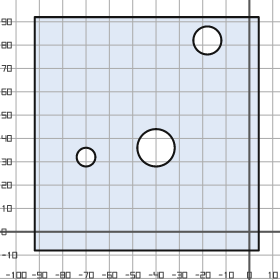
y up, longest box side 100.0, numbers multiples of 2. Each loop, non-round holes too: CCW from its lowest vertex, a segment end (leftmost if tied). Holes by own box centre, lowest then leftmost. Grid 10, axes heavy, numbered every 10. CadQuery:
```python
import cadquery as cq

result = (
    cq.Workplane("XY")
    .moveTo(-92.0, -8.0)
    .lineTo(4.0, -8.0)
    .lineTo(4.0, 92.0)
    .lineTo(-92.0, 92.0)
    .close()
    .moveTo(-70.0, 32.0)
    .circle(4.0)
    .moveTo(-40.0, 36.0)
    .circle(8.0)
    .moveTo(-18.0, 82.0)
    .circle(6.0)
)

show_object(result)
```